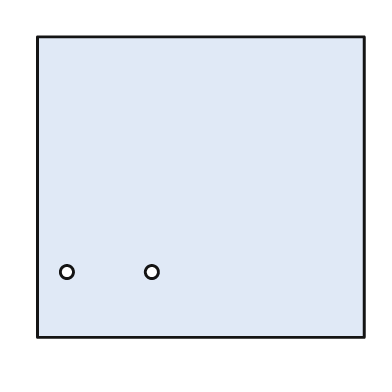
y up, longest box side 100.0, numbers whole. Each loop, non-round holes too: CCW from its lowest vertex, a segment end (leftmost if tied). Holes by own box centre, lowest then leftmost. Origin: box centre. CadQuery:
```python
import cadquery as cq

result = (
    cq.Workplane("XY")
    .moveTo(-50.0, -46.0)
    .lineTo(50.0, -46.0)
    .lineTo(50.0, 46.0)
    .lineTo(-50.0, 46.0)
    .close()
    .moveTo(-41.0, -26.0)
    .circle(2.0)
    .moveTo(-15.0, -26.0)
    .circle(2.0)
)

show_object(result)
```